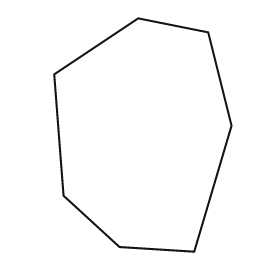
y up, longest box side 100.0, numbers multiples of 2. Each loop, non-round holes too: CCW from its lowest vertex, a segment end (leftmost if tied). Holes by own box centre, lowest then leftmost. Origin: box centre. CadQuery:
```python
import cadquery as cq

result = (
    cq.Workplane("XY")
    .moveTo(22.0, -50.0)
    .lineTo(38.0, 4.0)
    .lineTo(28.0, 44.0)
    .lineTo(-2.0, 50.0)
    .lineTo(-38.0, 26.0)
    .lineTo(-34.0, -26.0)
    .lineTo(-10.0, -48.0)
    .close()
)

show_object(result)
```